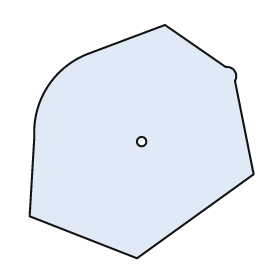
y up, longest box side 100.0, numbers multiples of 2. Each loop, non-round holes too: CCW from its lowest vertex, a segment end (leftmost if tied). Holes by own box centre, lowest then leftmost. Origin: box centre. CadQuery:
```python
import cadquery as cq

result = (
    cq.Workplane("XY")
    .moveTo(-2.0, -50.0)
    .lineTo(48.0, -14.0)
    .lineTo(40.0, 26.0)
    .threePointArc((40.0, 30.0), (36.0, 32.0))
    .lineTo(10.0, 50.0)
    .lineTo(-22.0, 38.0)
    .threePointArc((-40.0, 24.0), (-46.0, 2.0))
    .lineTo(-48.0, -32.0)
    .close()
    .moveTo(0.0, 0.0)
    .circle(2.0)
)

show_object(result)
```